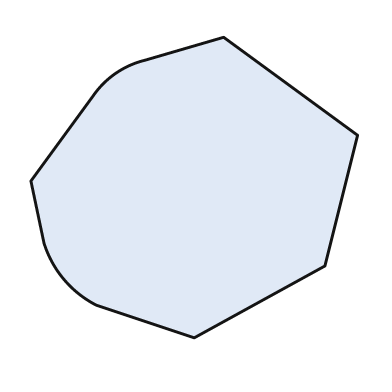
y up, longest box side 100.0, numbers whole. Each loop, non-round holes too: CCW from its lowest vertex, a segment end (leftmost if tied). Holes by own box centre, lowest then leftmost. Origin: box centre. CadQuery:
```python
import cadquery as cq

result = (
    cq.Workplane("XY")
    .moveTo(0.0, -46.0)
    .lineTo(40.0, -24.0)
    .lineTo(50.0, 16.0)
    .lineTo(9.0, 46.0)
    .lineTo(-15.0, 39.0)
    .threePointArc((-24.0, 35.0), (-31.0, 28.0))
    .lineTo(-50.0, 2.0)
    .lineTo(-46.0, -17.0)
    .threePointArc((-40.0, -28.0), (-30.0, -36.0))
    .close()
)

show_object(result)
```